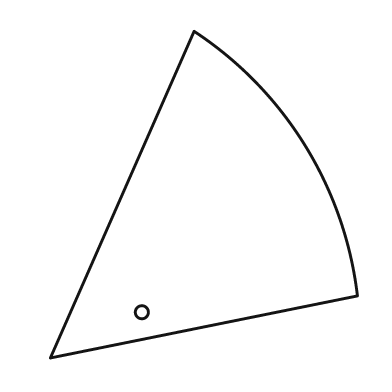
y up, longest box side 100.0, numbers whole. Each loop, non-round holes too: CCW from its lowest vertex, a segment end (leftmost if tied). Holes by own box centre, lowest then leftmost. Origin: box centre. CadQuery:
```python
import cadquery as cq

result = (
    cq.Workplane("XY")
    .moveTo(-47.0, -50.0)
    .lineTo(47.0, -31.0)
    .threePointArc((31.0, 15.0), (-3.0, 50.0))
    .close()
    .moveTo(-19.0, -36.0)
    .circle(2.0)
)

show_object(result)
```